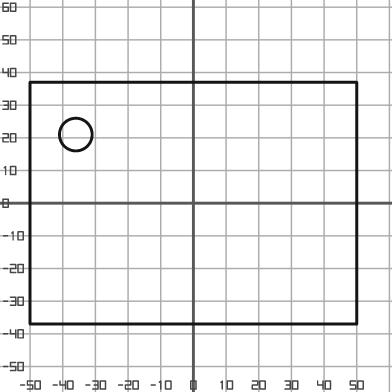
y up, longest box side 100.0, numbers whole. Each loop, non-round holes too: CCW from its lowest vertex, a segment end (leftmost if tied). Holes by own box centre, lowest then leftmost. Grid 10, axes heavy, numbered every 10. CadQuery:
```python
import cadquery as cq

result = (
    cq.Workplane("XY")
    .moveTo(-50.0, -37.0)
    .lineTo(50.0, -37.0)
    .lineTo(50.0, 37.0)
    .lineTo(-50.0, 37.0)
    .close()
    .moveTo(-36.0, 21.0)
    .circle(5.0)
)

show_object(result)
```